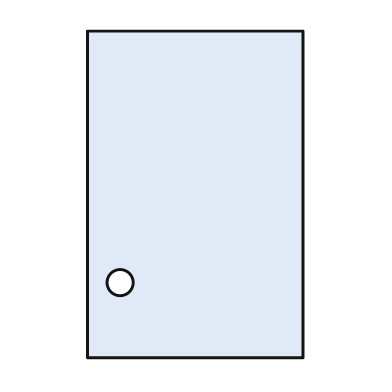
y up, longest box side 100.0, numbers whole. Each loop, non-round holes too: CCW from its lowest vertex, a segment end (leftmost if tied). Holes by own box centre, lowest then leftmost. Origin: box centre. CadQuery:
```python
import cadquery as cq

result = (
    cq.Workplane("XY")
    .moveTo(-33.0, -50.0)
    .lineTo(33.0, -50.0)
    .lineTo(33.0, 50.0)
    .lineTo(-33.0, 50.0)
    .close()
    .moveTo(-23.0, -27.0)
    .circle(4.0)
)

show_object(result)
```